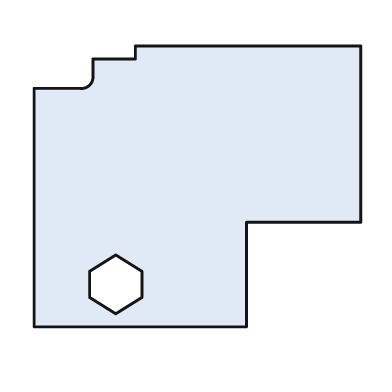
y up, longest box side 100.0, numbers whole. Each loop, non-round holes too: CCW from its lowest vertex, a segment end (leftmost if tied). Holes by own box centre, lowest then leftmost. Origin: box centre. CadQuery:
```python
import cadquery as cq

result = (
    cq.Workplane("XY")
    .moveTo(-50.0, -43.0)
    .lineTo(15.0, -43.0)
    .lineTo(15.0, -11.0)
    .lineTo(50.0, -11.0)
    .lineTo(50.0, 43.0)
    .lineTo(-19.0, 43.0)
    .lineTo(-19.0, 39.0)
    .lineTo(-32.0, 39.0)
    .lineTo(-32.0, 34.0)
    .threePointArc((-33.0, 31.0), (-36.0, 30.0))
    .lineTo(-50.0, 30.0)
    .close()
    .moveTo(-25.0, -39.0)
    .lineTo(-17.0, -34.0)
    .lineTo(-17.0, -26.0)
    .lineTo(-25.0, -21.0)
    .lineTo(-33.0, -26.0)
    .lineTo(-33.0, -34.0)
    .close()
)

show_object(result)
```